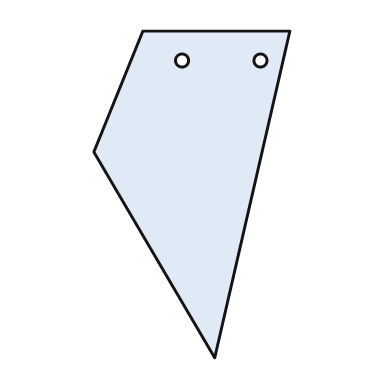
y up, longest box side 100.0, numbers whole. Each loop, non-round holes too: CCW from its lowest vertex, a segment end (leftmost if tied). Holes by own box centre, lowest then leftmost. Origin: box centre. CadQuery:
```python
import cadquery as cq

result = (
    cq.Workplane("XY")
    .moveTo(7.0, -50.0)
    .lineTo(30.0, 50.0)
    .lineTo(-15.0, 50.0)
    .lineTo(-30.0, 13.0)
    .close()
    .moveTo(-3.0, 41.0)
    .circle(2.0)
    .moveTo(21.0, 41.0)
    .circle(2.0)
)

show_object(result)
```